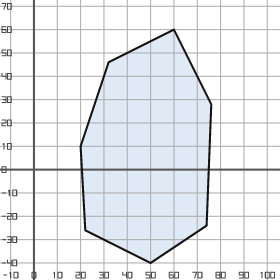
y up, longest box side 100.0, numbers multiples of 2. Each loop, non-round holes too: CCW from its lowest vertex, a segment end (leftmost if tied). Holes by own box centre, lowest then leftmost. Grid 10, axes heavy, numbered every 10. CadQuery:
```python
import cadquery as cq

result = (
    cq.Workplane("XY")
    .moveTo(50.0, -40.0)
    .lineTo(74.0, -24.0)
    .lineTo(76.0, 28.0)
    .lineTo(60.0, 60.0)
    .lineTo(32.0, 46.0)
    .lineTo(20.0, 10.0)
    .lineTo(22.0, -26.0)
    .close()
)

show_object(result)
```